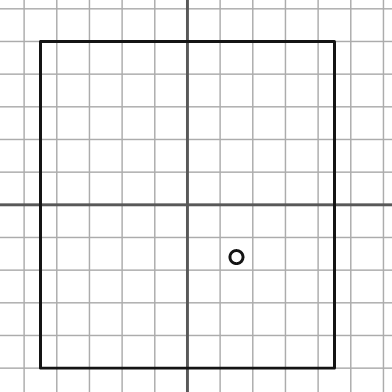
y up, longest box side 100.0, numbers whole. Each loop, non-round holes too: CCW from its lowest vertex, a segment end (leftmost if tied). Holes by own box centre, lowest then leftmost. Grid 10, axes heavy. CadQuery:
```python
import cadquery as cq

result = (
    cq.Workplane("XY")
    .moveTo(-45.0, -50.0)
    .lineTo(45.0, -50.0)
    .lineTo(45.0, 50.0)
    .lineTo(-45.0, 50.0)
    .close()
    .moveTo(15.0, -16.0)
    .circle(2.0)
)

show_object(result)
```